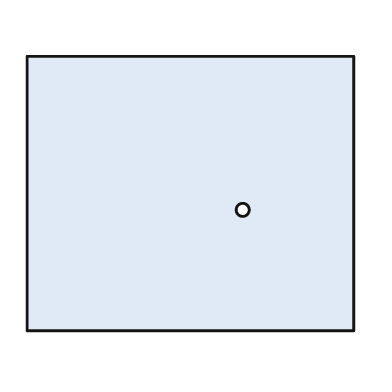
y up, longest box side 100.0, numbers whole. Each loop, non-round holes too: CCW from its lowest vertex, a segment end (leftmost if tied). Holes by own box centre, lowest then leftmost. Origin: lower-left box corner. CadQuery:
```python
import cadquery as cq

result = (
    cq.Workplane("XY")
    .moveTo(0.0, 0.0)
    .lineTo(100.0, 0.0)
    .lineTo(100.0, 84.0)
    .lineTo(0.0, 84.0)
    .close()
    .moveTo(66.0, 37.0)
    .circle(2.0)
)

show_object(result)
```